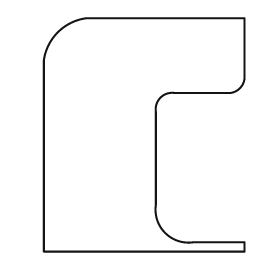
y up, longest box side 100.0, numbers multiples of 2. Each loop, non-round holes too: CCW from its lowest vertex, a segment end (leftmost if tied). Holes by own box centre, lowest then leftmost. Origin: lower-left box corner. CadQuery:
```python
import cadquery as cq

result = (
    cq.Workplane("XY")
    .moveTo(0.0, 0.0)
    .lineTo(86.0, 0.0)
    .lineTo(86.0, 4.0)
    .lineTo(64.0, 4.0)
    .threePointArc((52.0, 8.0), (48.0, 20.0))
    .lineTo(48.0, 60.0)
    .threePointArc((50.0, 66.0), (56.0, 68.0))
    .lineTo(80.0, 68.0)
    .threePointArc((84.0, 70.0), (86.0, 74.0))
    .lineTo(86.0, 100.0)
    .lineTo(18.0, 100.0)
    .threePointArc((6.0, 94.0), (0.0, 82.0))
    .close()
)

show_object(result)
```